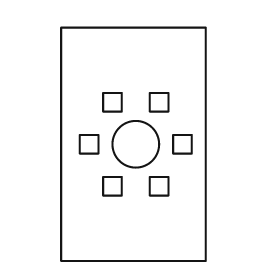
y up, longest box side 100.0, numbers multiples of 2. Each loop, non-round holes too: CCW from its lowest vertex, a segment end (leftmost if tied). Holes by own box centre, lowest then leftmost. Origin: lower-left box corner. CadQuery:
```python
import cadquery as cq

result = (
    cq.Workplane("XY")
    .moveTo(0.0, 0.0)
    .lineTo(62.0, 0.0)
    .lineTo(62.0, 100.0)
    .lineTo(0.0, 100.0)
    .close()
    .moveTo(18.0, 28.0)
    .lineTo(26.0, 28.0)
    .lineTo(26.0, 36.0)
    .lineTo(18.0, 36.0)
    .close()
    .moveTo(38.0, 28.0)
    .lineTo(46.0, 28.0)
    .lineTo(46.0, 36.0)
    .lineTo(38.0, 36.0)
    .close()
    .moveTo(8.0, 46.0)
    .lineTo(16.0, 46.0)
    .lineTo(16.0, 54.0)
    .lineTo(8.0, 54.0)
    .close()
    .moveTo(32.0, 50.0)
    .circle(10.0)
    .moveTo(48.0, 46.0)
    .lineTo(56.0, 46.0)
    .lineTo(56.0, 54.0)
    .lineTo(48.0, 54.0)
    .close()
    .moveTo(18.0, 64.0)
    .lineTo(26.0, 64.0)
    .lineTo(26.0, 72.0)
    .lineTo(18.0, 72.0)
    .close()
    .moveTo(38.0, 64.0)
    .lineTo(46.0, 64.0)
    .lineTo(46.0, 72.0)
    .lineTo(38.0, 72.0)
    .close()
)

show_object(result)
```